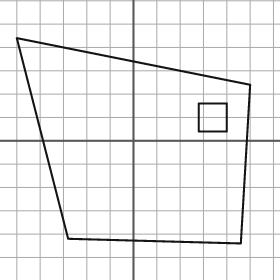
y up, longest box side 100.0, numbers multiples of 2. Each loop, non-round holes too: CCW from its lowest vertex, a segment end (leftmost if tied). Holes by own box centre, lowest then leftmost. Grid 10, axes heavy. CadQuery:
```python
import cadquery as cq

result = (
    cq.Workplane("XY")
    .moveTo(46.0, -44.0)
    .lineTo(50.0, 24.0)
    .lineTo(-50.0, 44.0)
    .lineTo(-28.0, -42.0)
    .close()
    .moveTo(28.0, 4.0)
    .lineTo(40.0, 4.0)
    .lineTo(40.0, 16.0)
    .lineTo(28.0, 16.0)
    .close()
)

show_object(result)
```